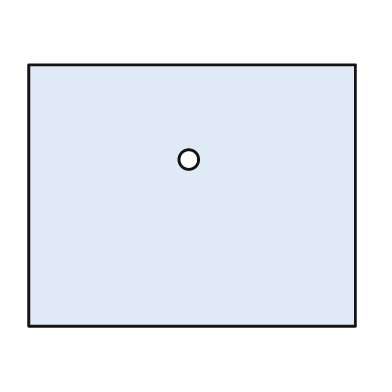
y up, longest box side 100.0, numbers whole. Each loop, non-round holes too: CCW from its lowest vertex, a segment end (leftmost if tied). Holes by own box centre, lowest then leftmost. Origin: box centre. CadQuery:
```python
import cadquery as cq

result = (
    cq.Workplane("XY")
    .moveTo(-50.0, -40.0)
    .lineTo(50.0, -40.0)
    .lineTo(50.0, 40.0)
    .lineTo(-50.0, 40.0)
    .close()
    .moveTo(-1.0, 11.0)
    .circle(3.0)
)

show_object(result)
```